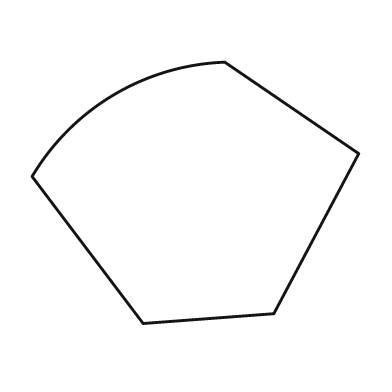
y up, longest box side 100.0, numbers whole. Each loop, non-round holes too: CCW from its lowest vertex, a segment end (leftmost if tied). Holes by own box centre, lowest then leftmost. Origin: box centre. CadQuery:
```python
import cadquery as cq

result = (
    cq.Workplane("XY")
    .moveTo(-16.0, -40.0)
    .lineTo(24.0, -37.0)
    .lineTo(50.0, 12.0)
    .lineTo(9.0, 40.0)
    .threePointArc((-25.0, 30.0), (-50.0, 5.0))
    .close()
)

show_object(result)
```